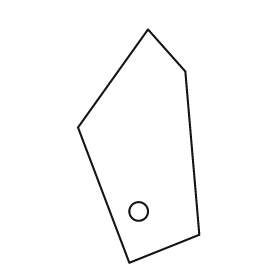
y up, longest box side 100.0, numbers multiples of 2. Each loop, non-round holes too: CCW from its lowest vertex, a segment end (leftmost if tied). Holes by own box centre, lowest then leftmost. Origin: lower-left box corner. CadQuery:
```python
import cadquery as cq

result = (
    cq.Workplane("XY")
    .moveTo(22.0, 0.0)
    .lineTo(52.0, 12.0)
    .lineTo(46.0, 82.0)
    .lineTo(30.0, 100.0)
    .lineTo(0.0, 58.0)
    .close()
    .moveTo(26.0, 22.0)
    .circle(4.0)
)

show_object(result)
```